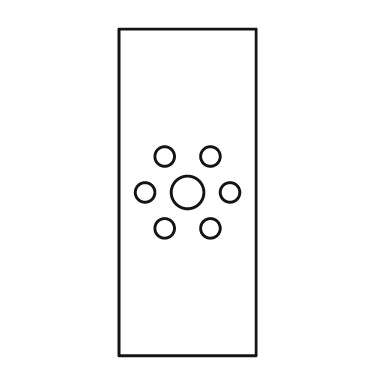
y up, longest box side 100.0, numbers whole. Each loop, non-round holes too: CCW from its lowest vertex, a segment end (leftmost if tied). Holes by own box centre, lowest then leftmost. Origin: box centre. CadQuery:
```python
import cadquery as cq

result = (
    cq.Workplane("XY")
    .moveTo(-21.0, -50.0)
    .lineTo(21.0, -50.0)
    .lineTo(21.0, 50.0)
    .lineTo(-21.0, 50.0)
    .close()
    .moveTo(-7.0, -11.0)
    .circle(3.0)
    .moveTo(7.0, -11.0)
    .circle(3.0)
    .moveTo(-13.0, 0.0)
    .circle(3.0)
    .moveTo(0.0, 0.0)
    .circle(5.0)
    .moveTo(13.0, 0.0)
    .circle(3.0)
    .moveTo(-7.0, 11.0)
    .circle(3.0)
    .moveTo(7.0, 11.0)
    .circle(3.0)
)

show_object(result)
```